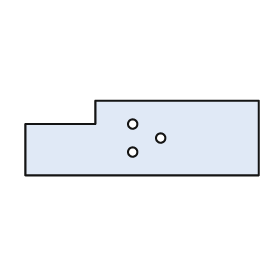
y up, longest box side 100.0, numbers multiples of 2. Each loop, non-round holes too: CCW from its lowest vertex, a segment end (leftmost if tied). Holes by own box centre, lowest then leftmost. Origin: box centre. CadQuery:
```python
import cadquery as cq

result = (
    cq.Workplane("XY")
    .moveTo(-50.0, -16.0)
    .lineTo(50.0, -16.0)
    .lineTo(50.0, 16.0)
    .lineTo(-20.0, 16.0)
    .lineTo(-20.0, 6.0)
    .lineTo(-50.0, 6.0)
    .close()
    .moveTo(-4.0, -6.0)
    .circle(2.0)
    .moveTo(8.0, 0.0)
    .circle(2.0)
    .moveTo(-4.0, 6.0)
    .circle(2.0)
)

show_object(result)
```